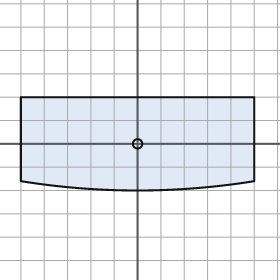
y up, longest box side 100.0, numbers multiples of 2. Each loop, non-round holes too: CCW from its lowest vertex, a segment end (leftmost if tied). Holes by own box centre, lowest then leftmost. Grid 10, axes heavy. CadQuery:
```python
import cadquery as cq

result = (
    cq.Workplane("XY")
    .moveTo(-50.0, -16.0)
    .threePointArc((0.0, -20.0), (50.0, -16.0))
    .lineTo(50.0, 20.0)
    .lineTo(-50.0, 20.0)
    .close()
    .moveTo(0.0, 0.0)
    .circle(2.0)
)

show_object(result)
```